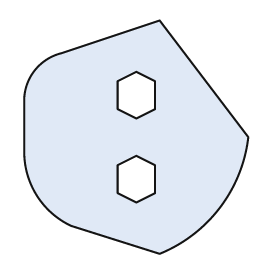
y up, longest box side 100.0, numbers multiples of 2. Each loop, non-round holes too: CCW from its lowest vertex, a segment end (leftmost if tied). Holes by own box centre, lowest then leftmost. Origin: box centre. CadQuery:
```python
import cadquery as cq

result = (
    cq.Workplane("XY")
    .moveTo(10.0, -50.0)
    .threePointArc((36.0, -30.0), (48.0, 0.0))
    .lineTo(10.0, 50.0)
    .lineTo(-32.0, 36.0)
    .threePointArc((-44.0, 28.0), (-48.0, 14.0))
    .lineTo(-48.0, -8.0)
    .threePointArc((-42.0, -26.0), (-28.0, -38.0))
    .close()
    .moveTo(0.0, -28.0)
    .lineTo(8.0, -24.0)
    .lineTo(8.0, -12.0)
    .lineTo(0.0, -8.0)
    .lineTo(-8.0, -12.0)
    .lineTo(-8.0, -24.0)
    .close()
    .moveTo(0.0, 8.0)
    .lineTo(8.0, 12.0)
    .lineTo(8.0, 24.0)
    .lineTo(0.0, 28.0)
    .lineTo(-8.0, 24.0)
    .lineTo(-8.0, 12.0)
    .close()
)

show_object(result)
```